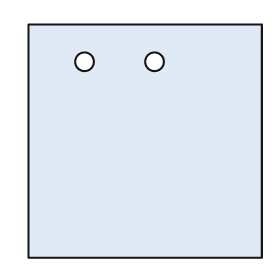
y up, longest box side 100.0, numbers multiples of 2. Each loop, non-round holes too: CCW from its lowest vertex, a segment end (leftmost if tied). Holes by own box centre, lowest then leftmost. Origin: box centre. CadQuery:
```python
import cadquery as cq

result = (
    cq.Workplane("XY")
    .moveTo(-50.0, -50.0)
    .lineTo(50.0, -50.0)
    .lineTo(50.0, 50.0)
    .lineTo(-50.0, 50.0)
    .close()
    .moveTo(-26.0, 34.0)
    .circle(4.0)
    .moveTo(4.0, 34.0)
    .circle(4.0)
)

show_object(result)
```